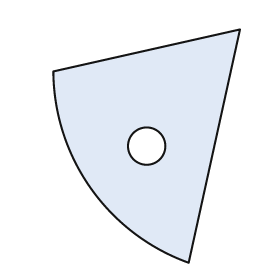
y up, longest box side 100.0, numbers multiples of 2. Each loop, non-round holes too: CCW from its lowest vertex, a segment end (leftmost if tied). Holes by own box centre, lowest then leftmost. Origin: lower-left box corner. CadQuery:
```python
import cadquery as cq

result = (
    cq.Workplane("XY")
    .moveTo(58.0, 0.0)
    .lineTo(80.0, 100.0)
    .lineTo(0.0, 82.0)
    .threePointArc((16.0, 32.0), (58.0, 0.0))
    .close()
    .moveTo(40.0, 50.0)
    .circle(8.0)
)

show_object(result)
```